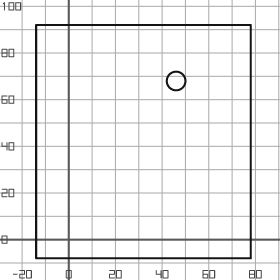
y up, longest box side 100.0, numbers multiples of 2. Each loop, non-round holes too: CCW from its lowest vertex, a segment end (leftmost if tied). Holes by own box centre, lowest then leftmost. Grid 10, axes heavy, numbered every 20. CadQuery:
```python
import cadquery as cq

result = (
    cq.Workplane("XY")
    .moveTo(-14.0, -8.0)
    .lineTo(78.0, -8.0)
    .lineTo(78.0, 92.0)
    .lineTo(-14.0, 92.0)
    .close()
    .moveTo(46.0, 68.0)
    .circle(4.0)
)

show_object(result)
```